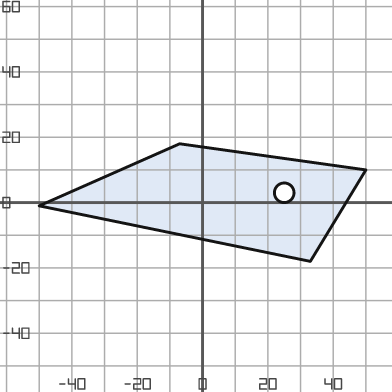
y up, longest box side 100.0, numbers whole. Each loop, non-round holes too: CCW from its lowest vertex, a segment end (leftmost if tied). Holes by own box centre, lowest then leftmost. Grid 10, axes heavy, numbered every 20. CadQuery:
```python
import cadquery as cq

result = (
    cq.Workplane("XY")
    .moveTo(33.0, -18.0)
    .lineTo(50.0, 10.0)
    .lineTo(-7.0, 18.0)
    .lineTo(-50.0, -1.0)
    .close()
    .moveTo(25.0, 3.0)
    .circle(3.0)
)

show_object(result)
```